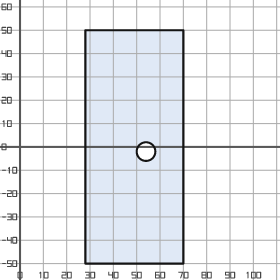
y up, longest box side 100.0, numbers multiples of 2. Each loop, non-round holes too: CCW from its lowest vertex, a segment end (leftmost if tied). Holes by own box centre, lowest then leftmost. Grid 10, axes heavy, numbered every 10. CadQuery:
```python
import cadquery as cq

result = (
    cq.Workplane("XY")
    .moveTo(28.0, -50.0)
    .lineTo(70.0, -50.0)
    .lineTo(70.0, 50.0)
    .lineTo(28.0, 50.0)
    .close()
    .moveTo(54.0, -2.0)
    .circle(4.0)
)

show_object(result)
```